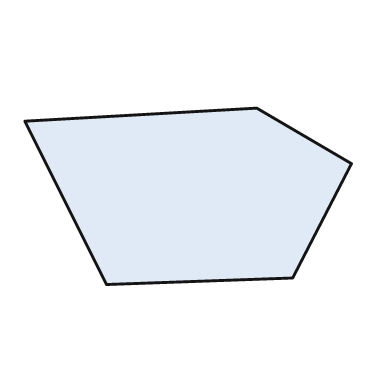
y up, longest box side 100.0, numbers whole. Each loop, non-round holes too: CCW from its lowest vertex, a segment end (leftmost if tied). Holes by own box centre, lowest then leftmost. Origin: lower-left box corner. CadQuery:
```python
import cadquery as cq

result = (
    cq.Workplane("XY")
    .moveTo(25.0, 0.0)
    .lineTo(82.0, 2.0)
    .lineTo(100.0, 37.0)
    .lineTo(71.0, 54.0)
    .lineTo(0.0, 50.0)
    .close()
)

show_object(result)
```